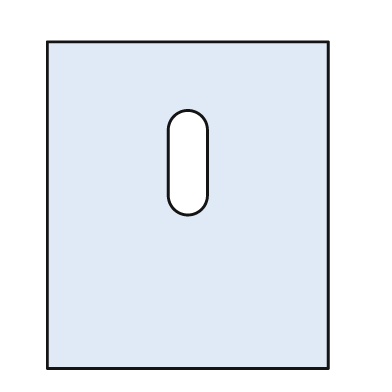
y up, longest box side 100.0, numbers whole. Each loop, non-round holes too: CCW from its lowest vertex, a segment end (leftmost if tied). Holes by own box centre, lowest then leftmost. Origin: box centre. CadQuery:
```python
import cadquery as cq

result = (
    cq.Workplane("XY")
    .moveTo(-43.0, -50.0)
    .lineTo(43.0, -50.0)
    .lineTo(43.0, 50.0)
    .lineTo(-43.0, 50.0)
    .close()
    .moveTo(-6.0, 3.0)
    .threePointArc((0.0, -3.0), (6.0, 3.0))
    .lineTo(6.0, 23.0)
    .threePointArc((0.0, 29.0), (-6.0, 23.0))
    .close()
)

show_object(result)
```